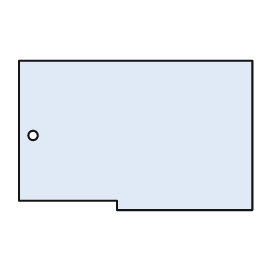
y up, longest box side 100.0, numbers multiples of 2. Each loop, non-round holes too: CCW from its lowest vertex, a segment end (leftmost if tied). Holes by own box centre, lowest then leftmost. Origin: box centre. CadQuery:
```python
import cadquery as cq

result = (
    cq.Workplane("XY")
    .moveTo(-8.0, -32.0)
    .lineTo(50.0, -32.0)
    .lineTo(50.0, 32.0)
    .lineTo(-50.0, 32.0)
    .lineTo(-50.0, -28.0)
    .lineTo(-8.0, -28.0)
    .close()
    .moveTo(-44.0, 0.0)
    .circle(2.0)
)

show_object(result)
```